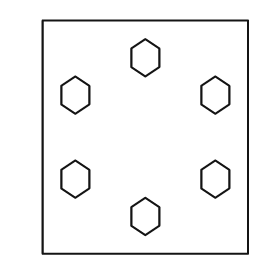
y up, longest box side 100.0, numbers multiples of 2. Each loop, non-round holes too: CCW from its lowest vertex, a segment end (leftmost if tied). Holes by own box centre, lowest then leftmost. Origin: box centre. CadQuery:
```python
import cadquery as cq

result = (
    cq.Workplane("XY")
    .moveTo(-44.0, -50.0)
    .lineTo(44.0, -50.0)
    .lineTo(44.0, 50.0)
    .lineTo(-44.0, 50.0)
    .close()
    .moveTo(0.0, -42.0)
    .lineTo(6.0, -38.0)
    .lineTo(6.0, -30.0)
    .lineTo(0.0, -26.0)
    .lineTo(-6.0, -30.0)
    .lineTo(-6.0, -38.0)
    .close()
    .moveTo(-30.0, -26.0)
    .lineTo(-24.0, -22.0)
    .lineTo(-24.0, -14.0)
    .lineTo(-30.0, -10.0)
    .lineTo(-36.0, -14.0)
    .lineTo(-36.0, -22.0)
    .close()
    .moveTo(30.0, -26.0)
    .lineTo(36.0, -22.0)
    .lineTo(36.0, -14.0)
    .lineTo(30.0, -10.0)
    .lineTo(24.0, -14.0)
    .lineTo(24.0, -22.0)
    .close()
    .moveTo(-30.0, 10.0)
    .lineTo(-24.0, 14.0)
    .lineTo(-24.0, 22.0)
    .lineTo(-30.0, 26.0)
    .lineTo(-36.0, 22.0)
    .lineTo(-36.0, 14.0)
    .close()
    .moveTo(30.0, 10.0)
    .lineTo(36.0, 14.0)
    .lineTo(36.0, 22.0)
    .lineTo(30.0, 26.0)
    .lineTo(24.0, 22.0)
    .lineTo(24.0, 14.0)
    .close()
    .moveTo(0.0, 26.0)
    .lineTo(6.0, 30.0)
    .lineTo(6.0, 38.0)
    .lineTo(0.0, 42.0)
    .lineTo(-6.0, 38.0)
    .lineTo(-6.0, 30.0)
    .close()
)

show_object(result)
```